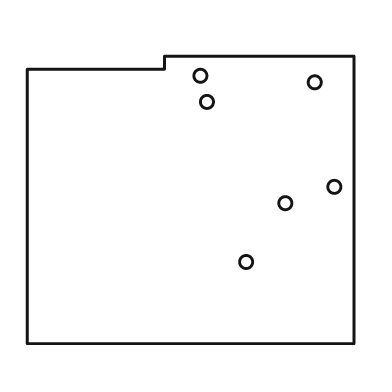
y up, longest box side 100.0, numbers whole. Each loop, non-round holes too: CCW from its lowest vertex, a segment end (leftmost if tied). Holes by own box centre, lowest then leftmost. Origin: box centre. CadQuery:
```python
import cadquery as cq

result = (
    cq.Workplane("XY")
    .moveTo(-50.0, -44.0)
    .lineTo(50.0, -44.0)
    .lineTo(50.0, 44.0)
    .lineTo(-8.0, 44.0)
    .lineTo(-8.0, 40.0)
    .lineTo(-50.0, 40.0)
    .close()
    .moveTo(17.0, -19.0)
    .circle(2.0)
    .moveTo(29.0, -1.0)
    .circle(2.0)
    .moveTo(44.0, 4.0)
    .circle(2.0)
    .moveTo(5.0, 30.0)
    .circle(2.0)
    .moveTo(38.0, 36.0)
    .circle(2.0)
    .moveTo(3.0, 38.0)
    .circle(2.0)
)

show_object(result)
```